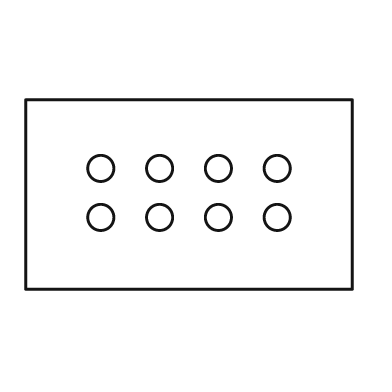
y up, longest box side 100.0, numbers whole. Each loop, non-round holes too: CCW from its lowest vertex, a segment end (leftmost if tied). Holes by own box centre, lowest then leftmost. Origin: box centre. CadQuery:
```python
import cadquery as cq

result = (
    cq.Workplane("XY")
    .moveTo(-50.0, -29.0)
    .lineTo(50.0, -29.0)
    .lineTo(50.0, 29.0)
    .lineTo(-50.0, 29.0)
    .close()
    .moveTo(-27.0, -7.0)
    .circle(4.0)
    .moveTo(-9.0, -7.0)
    .circle(4.0)
    .moveTo(9.0, -7.0)
    .circle(4.0)
    .moveTo(27.0, -7.0)
    .circle(4.0)
    .moveTo(-27.0, 8.0)
    .circle(4.0)
    .moveTo(-9.0, 8.0)
    .circle(4.0)
    .moveTo(9.0, 8.0)
    .circle(4.0)
    .moveTo(27.0, 8.0)
    .circle(4.0)
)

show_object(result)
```